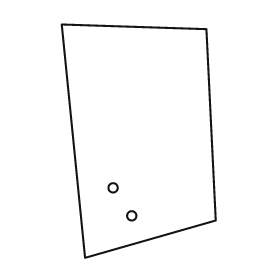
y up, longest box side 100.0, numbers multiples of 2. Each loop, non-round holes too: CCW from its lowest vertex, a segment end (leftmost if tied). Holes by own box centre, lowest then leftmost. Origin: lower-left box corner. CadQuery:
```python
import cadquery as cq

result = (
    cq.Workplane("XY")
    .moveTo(10.0, 0.0)
    .lineTo(66.0, 16.0)
    .lineTo(62.0, 98.0)
    .lineTo(0.0, 100.0)
    .close()
    .moveTo(30.0, 18.0)
    .circle(2.0)
    .moveTo(22.0, 30.0)
    .circle(2.0)
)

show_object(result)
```